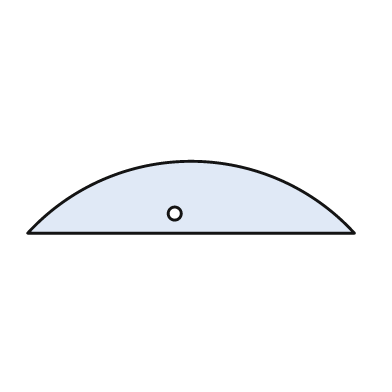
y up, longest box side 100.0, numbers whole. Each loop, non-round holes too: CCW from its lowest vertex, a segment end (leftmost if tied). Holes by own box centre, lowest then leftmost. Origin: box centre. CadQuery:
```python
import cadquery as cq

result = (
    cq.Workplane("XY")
    .moveTo(-50.0, -11.0)
    .lineTo(50.0, -11.0)
    .threePointArc((0.0, 11.0), (-50.0, -11.0))
    .close()
    .moveTo(-5.0, -5.0)
    .circle(2.0)
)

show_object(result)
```